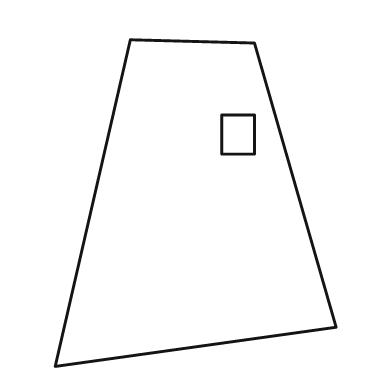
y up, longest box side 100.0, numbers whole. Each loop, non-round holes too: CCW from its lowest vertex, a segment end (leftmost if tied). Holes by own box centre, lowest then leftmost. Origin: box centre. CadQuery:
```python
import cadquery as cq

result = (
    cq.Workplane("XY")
    .moveTo(-43.0, -50.0)
    .lineTo(43.0, -38.0)
    .lineTo(18.0, 49.0)
    .lineTo(-20.0, 50.0)
    .close()
    .moveTo(8.0, 15.0)
    .lineTo(18.0, 15.0)
    .lineTo(18.0, 27.0)
    .lineTo(8.0, 27.0)
    .close()
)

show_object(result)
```